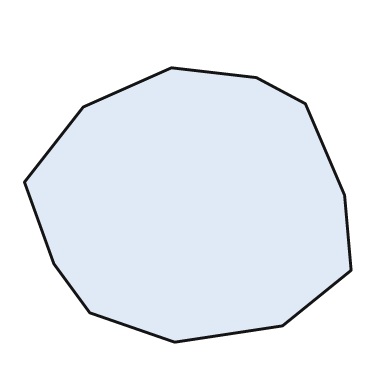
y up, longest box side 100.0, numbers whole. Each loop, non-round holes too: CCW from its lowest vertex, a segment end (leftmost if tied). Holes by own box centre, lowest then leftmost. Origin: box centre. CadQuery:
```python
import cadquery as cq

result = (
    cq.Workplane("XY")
    .moveTo(-4.0, -42.0)
    .lineTo(29.0, -37.0)
    .lineTo(50.0, -20.0)
    .lineTo(48.0, 3.0)
    .lineTo(36.0, 31.0)
    .lineTo(21.0, 39.0)
    .lineTo(-5.0, 42.0)
    .lineTo(-32.0, 30.0)
    .lineTo(-50.0, 7.0)
    .lineTo(-41.0, -18.0)
    .lineTo(-30.0, -33.0)
    .close()
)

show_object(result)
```